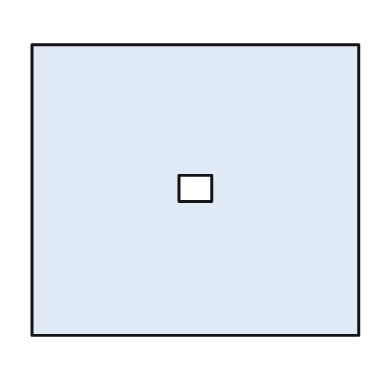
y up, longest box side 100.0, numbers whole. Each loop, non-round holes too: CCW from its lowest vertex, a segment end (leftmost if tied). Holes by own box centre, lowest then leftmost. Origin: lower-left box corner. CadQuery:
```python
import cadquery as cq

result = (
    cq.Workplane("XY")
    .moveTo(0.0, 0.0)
    .lineTo(100.0, 0.0)
    .lineTo(100.0, 89.0)
    .lineTo(0.0, 89.0)
    .close()
    .moveTo(45.0, 41.0)
    .lineTo(55.0, 41.0)
    .lineTo(55.0, 49.0)
    .lineTo(45.0, 49.0)
    .close()
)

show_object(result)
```